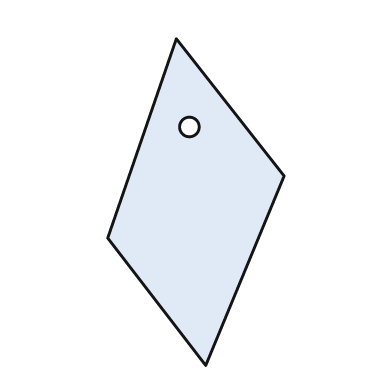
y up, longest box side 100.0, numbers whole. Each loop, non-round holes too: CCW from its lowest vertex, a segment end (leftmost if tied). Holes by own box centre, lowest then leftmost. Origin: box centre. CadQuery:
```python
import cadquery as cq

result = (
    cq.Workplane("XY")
    .moveTo(3.0, -50.0)
    .lineTo(27.0, 8.0)
    .lineTo(-6.0, 50.0)
    .lineTo(-27.0, -11.0)
    .close()
    .moveTo(-2.0, 23.0)
    .circle(3.0)
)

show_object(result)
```